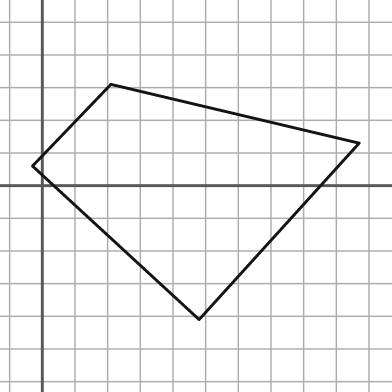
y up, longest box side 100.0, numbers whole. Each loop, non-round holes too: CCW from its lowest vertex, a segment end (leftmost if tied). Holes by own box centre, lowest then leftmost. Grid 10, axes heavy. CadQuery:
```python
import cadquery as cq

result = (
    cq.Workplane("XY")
    .moveTo(48.0, -41.0)
    .lineTo(97.0, 13.0)
    .lineTo(21.0, 31.0)
    .lineTo(-3.0, 6.0)
    .close()
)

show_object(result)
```